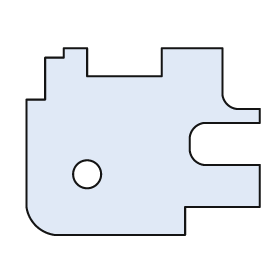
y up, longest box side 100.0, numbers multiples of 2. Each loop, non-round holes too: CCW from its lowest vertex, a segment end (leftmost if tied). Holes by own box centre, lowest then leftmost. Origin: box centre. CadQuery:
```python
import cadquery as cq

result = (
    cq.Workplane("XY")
    .moveTo(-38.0, -40.0)
    .lineTo(18.0, -40.0)
    .lineTo(18.0, -28.0)
    .lineTo(50.0, -28.0)
    .lineTo(50.0, -10.0)
    .lineTo(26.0, -10.0)
    .threePointArc((22.0, -8.0), (20.0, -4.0))
    .lineTo(20.0, 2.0)
    .threePointArc((22.0, 6.0), (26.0, 8.0))
    .lineTo(50.0, 8.0)
    .lineTo(50.0, 14.0)
    .lineTo(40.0, 14.0)
    .threePointArc((36.0, 16.0), (34.0, 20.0))
    .lineTo(34.0, 40.0)
    .lineTo(8.0, 40.0)
    .lineTo(8.0, 28.0)
    .lineTo(-24.0, 28.0)
    .lineTo(-24.0, 40.0)
    .lineTo(-34.0, 40.0)
    .lineTo(-34.0, 36.0)
    .lineTo(-42.0, 36.0)
    .lineTo(-42.0, 18.0)
    .lineTo(-50.0, 18.0)
    .lineTo(-50.0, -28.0)
    .threePointArc((-46.0, -36.0), (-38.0, -40.0))
    .close()
    .moveTo(-24.0, -14.0)
    .circle(6.0)
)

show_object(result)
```